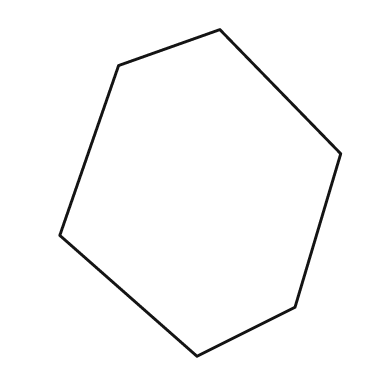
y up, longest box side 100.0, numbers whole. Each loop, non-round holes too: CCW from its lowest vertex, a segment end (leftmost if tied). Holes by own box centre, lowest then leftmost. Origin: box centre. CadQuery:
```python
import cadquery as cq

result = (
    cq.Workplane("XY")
    .moveTo(-1.0, -50.0)
    .lineTo(29.0, -35.0)
    .lineTo(43.0, 12.0)
    .lineTo(6.0, 50.0)
    .lineTo(-25.0, 39.0)
    .lineTo(-43.0, -13.0)
    .close()
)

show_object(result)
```